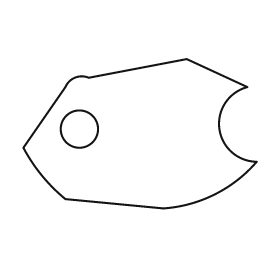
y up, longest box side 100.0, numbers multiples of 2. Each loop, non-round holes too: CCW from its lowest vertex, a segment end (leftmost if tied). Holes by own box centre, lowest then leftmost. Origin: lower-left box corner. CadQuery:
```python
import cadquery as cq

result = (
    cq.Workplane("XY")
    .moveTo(60.0, 0.0)
    .threePointArc((82.0, 6.0), (100.0, 20.0))
    .threePointArc((84.0, 34.0), (96.0, 52.0))
    .lineTo(70.0, 64.0)
    .lineTo(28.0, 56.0)
    .threePointArc((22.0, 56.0), (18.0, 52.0))
    .lineTo(0.0, 26.0)
    .threePointArc((8.0, 14.0), (18.0, 4.0))
    .close()
    .moveTo(24.0, 34.0)
    .circle(8.0)
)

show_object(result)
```